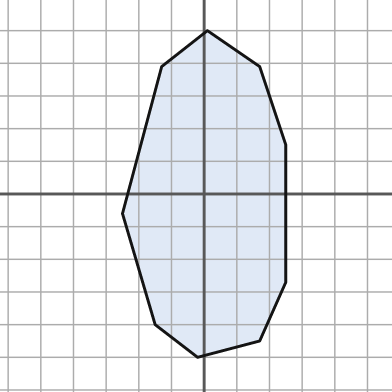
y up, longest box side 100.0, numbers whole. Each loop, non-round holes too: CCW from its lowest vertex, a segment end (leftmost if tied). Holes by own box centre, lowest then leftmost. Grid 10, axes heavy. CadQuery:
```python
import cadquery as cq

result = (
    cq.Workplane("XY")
    .moveTo(-2.0, -50.0)
    .lineTo(17.0, -45.0)
    .lineTo(25.0, -27.0)
    .lineTo(25.0, 15.0)
    .lineTo(17.0, 39.0)
    .lineTo(1.0, 50.0)
    .lineTo(-13.0, 39.0)
    .lineTo(-25.0, -6.0)
    .lineTo(-15.0, -40.0)
    .close()
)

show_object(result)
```